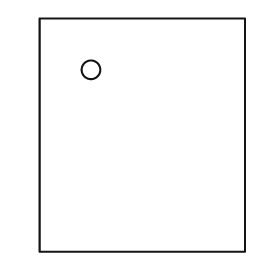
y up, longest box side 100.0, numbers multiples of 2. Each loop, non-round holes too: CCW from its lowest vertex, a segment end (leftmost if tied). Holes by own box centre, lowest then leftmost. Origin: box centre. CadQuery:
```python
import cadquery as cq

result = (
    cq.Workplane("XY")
    .moveTo(-44.0, -50.0)
    .lineTo(44.0, -50.0)
    .lineTo(44.0, 50.0)
    .lineTo(-44.0, 50.0)
    .close()
    .moveTo(-22.0, 28.0)
    .circle(4.0)
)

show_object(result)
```